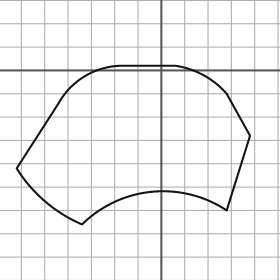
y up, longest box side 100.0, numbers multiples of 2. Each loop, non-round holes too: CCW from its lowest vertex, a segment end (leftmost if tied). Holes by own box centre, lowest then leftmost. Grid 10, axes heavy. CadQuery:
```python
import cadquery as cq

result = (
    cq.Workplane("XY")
    .moveTo(-34.0, -66.0)
    .threePointArc((-4.0, -52.0), (28.0, -60.0))
    .lineTo(38.0, -28.0)
    .lineTo(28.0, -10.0)
    .threePointArc((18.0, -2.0), (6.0, 2.0))
    .lineTo(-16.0, 2.0)
    .threePointArc((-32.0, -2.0), (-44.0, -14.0))
    .lineTo(-62.0, -42.0)
    .threePointArc((-50.0, -56.0), (-34.0, -66.0))
    .close()
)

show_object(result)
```